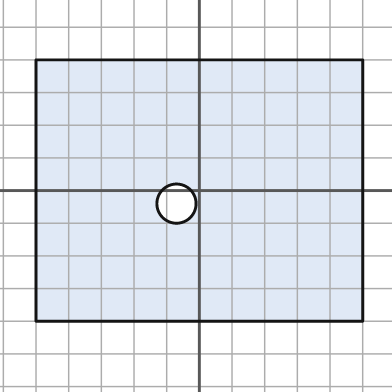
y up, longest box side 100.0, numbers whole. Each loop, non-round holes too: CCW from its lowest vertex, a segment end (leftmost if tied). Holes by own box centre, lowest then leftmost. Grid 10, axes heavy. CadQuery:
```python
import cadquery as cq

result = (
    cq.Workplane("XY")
    .moveTo(-50.0, -40.0)
    .lineTo(50.0, -40.0)
    .lineTo(50.0, 40.0)
    .lineTo(-50.0, 40.0)
    .close()
    .moveTo(-7.0, -4.0)
    .circle(6.0)
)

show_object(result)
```